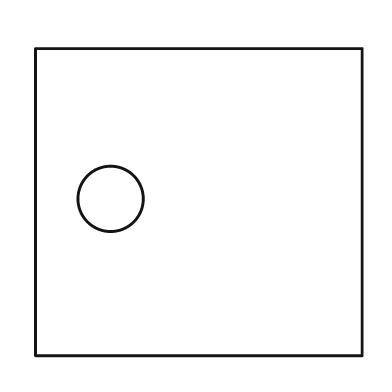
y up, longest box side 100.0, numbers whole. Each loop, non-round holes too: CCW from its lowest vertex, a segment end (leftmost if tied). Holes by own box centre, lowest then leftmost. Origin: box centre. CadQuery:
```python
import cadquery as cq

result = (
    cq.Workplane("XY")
    .moveTo(-50.0, -47.0)
    .lineTo(50.0, -47.0)
    .lineTo(50.0, 47.0)
    .lineTo(-50.0, 47.0)
    .close()
    .moveTo(-27.0, 1.0)
    .circle(10.0)
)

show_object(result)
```